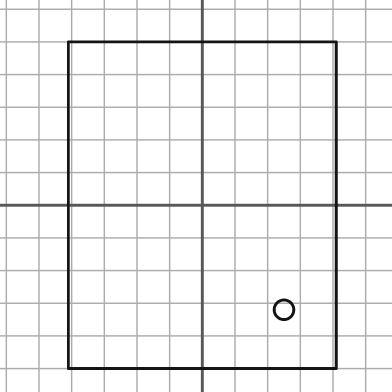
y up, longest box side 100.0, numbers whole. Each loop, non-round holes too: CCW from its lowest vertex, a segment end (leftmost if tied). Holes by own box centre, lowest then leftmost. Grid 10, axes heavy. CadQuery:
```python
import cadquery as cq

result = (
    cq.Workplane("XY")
    .moveTo(-41.0, -50.0)
    .lineTo(41.0, -50.0)
    .lineTo(41.0, 50.0)
    .lineTo(-41.0, 50.0)
    .close()
    .moveTo(25.0, -32.0)
    .circle(3.0)
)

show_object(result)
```